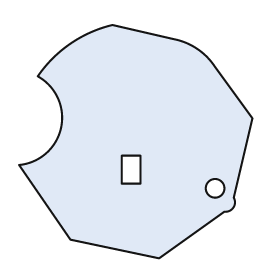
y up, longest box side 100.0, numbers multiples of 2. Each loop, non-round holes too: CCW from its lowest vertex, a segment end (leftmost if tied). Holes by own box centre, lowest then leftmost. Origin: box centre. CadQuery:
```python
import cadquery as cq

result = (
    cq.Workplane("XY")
    .moveTo(10.0, -50.0)
    .lineTo(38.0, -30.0)
    .threePointArc((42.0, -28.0), (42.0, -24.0))
    .lineTo(50.0, 10.0)
    .lineTo(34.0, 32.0)
    .threePointArc((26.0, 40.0), (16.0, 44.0))
    .lineTo(-10.0, 50.0)
    .threePointArc((-28.0, 42.0), (-42.0, 28.0))
    .threePointArc((-32.0, 6.0), (-50.0, -10.0))
    .lineTo(-28.0, -42.0)
    .close()
    .moveTo(34.0, -20.0)
    .circle(4.0)
    .moveTo(-6.0, -18.0)
    .lineTo(2.0, -18.0)
    .lineTo(2.0, -6.0)
    .lineTo(-6.0, -6.0)
    .close()
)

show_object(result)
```